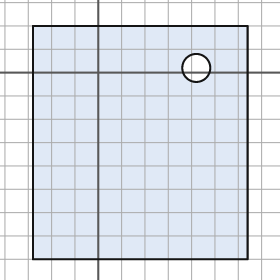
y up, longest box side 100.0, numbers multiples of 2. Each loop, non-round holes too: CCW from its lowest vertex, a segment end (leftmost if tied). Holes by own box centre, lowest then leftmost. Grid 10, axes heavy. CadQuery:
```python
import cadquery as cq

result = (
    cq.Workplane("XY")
    .moveTo(-28.0, -80.0)
    .lineTo(64.0, -80.0)
    .lineTo(64.0, 20.0)
    .lineTo(-28.0, 20.0)
    .close()
    .moveTo(42.0, 2.0)
    .circle(6.0)
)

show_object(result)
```